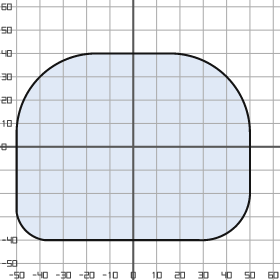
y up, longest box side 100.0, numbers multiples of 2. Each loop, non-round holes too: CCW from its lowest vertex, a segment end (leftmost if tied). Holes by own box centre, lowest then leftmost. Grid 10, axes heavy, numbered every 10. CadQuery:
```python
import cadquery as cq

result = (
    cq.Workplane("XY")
    .moveTo(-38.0, -40.0)
    .lineTo(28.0, -40.0)
    .threePointArc((44.0, -34.0), (50.0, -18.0))
    .lineTo(50.0, 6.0)
    .threePointArc((40.0, 30.0), (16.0, 40.0))
    .lineTo(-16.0, 40.0)
    .threePointArc((-40.0, 30.0), (-50.0, 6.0))
    .lineTo(-50.0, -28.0)
    .threePointArc((-46.0, -36.0), (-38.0, -40.0))
    .close()
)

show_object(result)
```